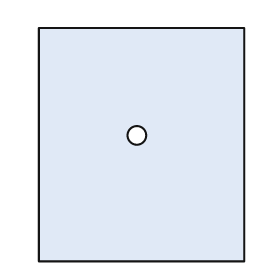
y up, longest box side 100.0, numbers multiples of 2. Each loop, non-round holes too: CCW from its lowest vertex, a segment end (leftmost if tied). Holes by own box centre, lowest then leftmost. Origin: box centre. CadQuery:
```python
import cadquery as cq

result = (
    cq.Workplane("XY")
    .moveTo(-44.0, -50.0)
    .lineTo(44.0, -50.0)
    .lineTo(44.0, 50.0)
    .lineTo(-44.0, 50.0)
    .close()
    .moveTo(-2.0, 4.0)
    .circle(4.0)
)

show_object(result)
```